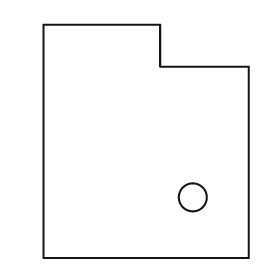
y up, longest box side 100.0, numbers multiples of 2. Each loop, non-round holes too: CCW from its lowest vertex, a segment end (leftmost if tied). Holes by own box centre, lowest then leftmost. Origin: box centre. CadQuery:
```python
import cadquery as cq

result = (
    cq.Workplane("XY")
    .moveTo(-44.0, -50.0)
    .lineTo(44.0, -50.0)
    .lineTo(44.0, 32.0)
    .lineTo(6.0, 32.0)
    .lineTo(6.0, 50.0)
    .lineTo(-44.0, 50.0)
    .close()
    .moveTo(20.0, -24.0)
    .circle(6.0)
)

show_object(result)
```